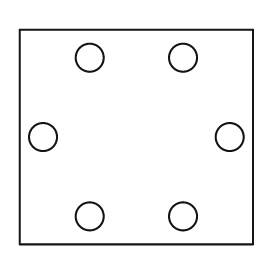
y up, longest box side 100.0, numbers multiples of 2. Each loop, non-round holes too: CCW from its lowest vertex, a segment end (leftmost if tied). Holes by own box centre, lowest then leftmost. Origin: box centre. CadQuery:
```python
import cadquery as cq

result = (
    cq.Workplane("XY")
    .moveTo(-50.0, -46.0)
    .lineTo(50.0, -46.0)
    .lineTo(50.0, 46.0)
    .lineTo(-50.0, 46.0)
    .close()
    .moveTo(-20.0, -34.0)
    .circle(6.0)
    .moveTo(20.0, -34.0)
    .circle(6.0)
    .moveTo(-40.0, 0.0)
    .circle(6.0)
    .moveTo(40.0, 0.0)
    .circle(6.0)
    .moveTo(-20.0, 34.0)
    .circle(6.0)
    .moveTo(20.0, 34.0)
    .circle(6.0)
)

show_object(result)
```